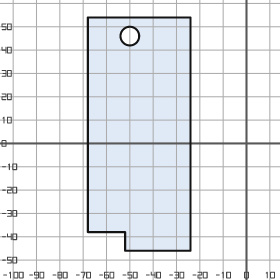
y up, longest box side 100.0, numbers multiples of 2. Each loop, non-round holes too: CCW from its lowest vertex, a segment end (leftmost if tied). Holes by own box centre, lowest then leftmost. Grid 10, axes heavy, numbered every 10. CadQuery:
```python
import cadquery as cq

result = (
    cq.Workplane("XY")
    .moveTo(-52.0, -46.0)
    .lineTo(-24.0, -46.0)
    .lineTo(-24.0, 54.0)
    .lineTo(-68.0, 54.0)
    .lineTo(-68.0, -38.0)
    .lineTo(-52.0, -38.0)
    .close()
    .moveTo(-50.0, 46.0)
    .circle(4.0)
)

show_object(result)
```